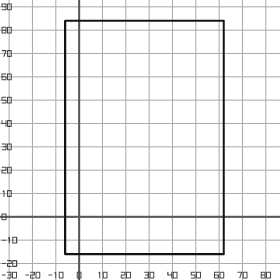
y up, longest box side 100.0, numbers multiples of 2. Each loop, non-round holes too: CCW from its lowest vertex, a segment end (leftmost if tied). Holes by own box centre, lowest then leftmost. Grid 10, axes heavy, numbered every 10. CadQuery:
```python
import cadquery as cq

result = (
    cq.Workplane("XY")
    .moveTo(-6.0, -16.0)
    .lineTo(62.0, -16.0)
    .lineTo(62.0, 84.0)
    .lineTo(-6.0, 84.0)
    .close()
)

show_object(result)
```